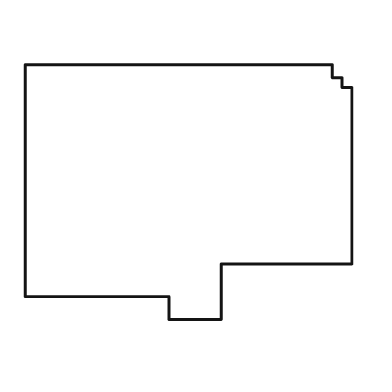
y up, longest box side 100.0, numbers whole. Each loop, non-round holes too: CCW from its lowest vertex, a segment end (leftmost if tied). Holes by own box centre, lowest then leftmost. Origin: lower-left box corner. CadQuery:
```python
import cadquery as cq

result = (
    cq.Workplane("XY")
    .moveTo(44.0, 0.0)
    .lineTo(60.0, 0.0)
    .lineTo(60.0, 17.0)
    .lineTo(100.0, 17.0)
    .lineTo(100.0, 71.0)
    .lineTo(97.0, 71.0)
    .lineTo(97.0, 74.0)
    .lineTo(94.0, 74.0)
    .lineTo(94.0, 78.0)
    .lineTo(0.0, 78.0)
    .lineTo(0.0, 7.0)
    .lineTo(44.0, 7.0)
    .close()
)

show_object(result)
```